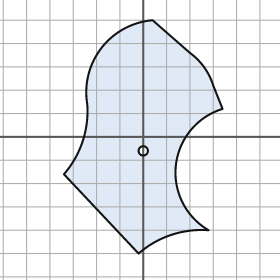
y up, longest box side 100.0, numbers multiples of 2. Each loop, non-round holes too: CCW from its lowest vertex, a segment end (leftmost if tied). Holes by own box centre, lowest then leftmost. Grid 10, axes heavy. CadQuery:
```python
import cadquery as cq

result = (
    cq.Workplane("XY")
    .moveTo(-2.0, -50.0)
    .threePointArc((12.0, -42.0), (28.0, -40.0))
    .threePointArc((14.0, -12.0), (34.0, 12.0))
    .lineTo(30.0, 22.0)
    .threePointArc((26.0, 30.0), (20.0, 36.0))
    .lineTo(4.0, 50.0)
    .threePointArc((-18.0, 38.0), (-24.0, 14.0))
    .threePointArc((-26.0, -2.0), (-34.0, -16.0))
    .close()
    .moveTo(0.0, -6.0)
    .circle(2.0)
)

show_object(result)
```